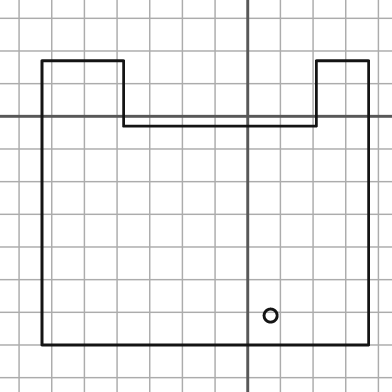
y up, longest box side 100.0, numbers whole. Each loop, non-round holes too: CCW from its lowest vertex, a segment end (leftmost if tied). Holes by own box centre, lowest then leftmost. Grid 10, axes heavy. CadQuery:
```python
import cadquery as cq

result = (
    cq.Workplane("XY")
    .moveTo(-63.0, -70.0)
    .lineTo(37.0, -70.0)
    .lineTo(37.0, 17.0)
    .lineTo(21.0, 17.0)
    .lineTo(21.0, -3.0)
    .lineTo(-38.0, -3.0)
    .lineTo(-38.0, 17.0)
    .lineTo(-63.0, 17.0)
    .close()
    .moveTo(7.0, -61.0)
    .circle(2.0)
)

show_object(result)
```